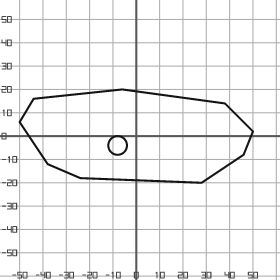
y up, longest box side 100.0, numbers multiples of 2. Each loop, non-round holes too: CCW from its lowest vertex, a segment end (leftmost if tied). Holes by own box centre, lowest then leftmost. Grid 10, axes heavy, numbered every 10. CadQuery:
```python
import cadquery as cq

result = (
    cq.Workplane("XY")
    .moveTo(28.0, -20.0)
    .lineTo(46.0, -8.0)
    .lineTo(50.0, 2.0)
    .lineTo(38.0, 14.0)
    .lineTo(-6.0, 20.0)
    .lineTo(-44.0, 16.0)
    .lineTo(-50.0, 6.0)
    .lineTo(-38.0, -12.0)
    .lineTo(-24.0, -18.0)
    .close()
    .moveTo(-8.0, -4.0)
    .circle(4.0)
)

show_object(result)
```